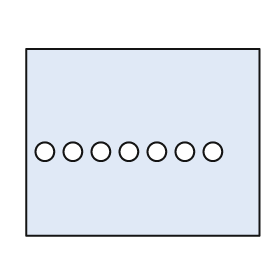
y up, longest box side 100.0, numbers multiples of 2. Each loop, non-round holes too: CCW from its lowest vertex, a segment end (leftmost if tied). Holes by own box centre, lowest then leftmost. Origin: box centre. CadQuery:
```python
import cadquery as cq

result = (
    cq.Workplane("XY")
    .moveTo(-50.0, -40.0)
    .lineTo(50.0, -40.0)
    .lineTo(50.0, 40.0)
    .lineTo(-50.0, 40.0)
    .close()
    .moveTo(-42.0, -4.0)
    .circle(4.0)
    .moveTo(-30.0, -4.0)
    .circle(4.0)
    .moveTo(-18.0, -4.0)
    .circle(4.0)
    .moveTo(-6.0, -4.0)
    .circle(4.0)
    .moveTo(6.0, -4.0)
    .circle(4.0)
    .moveTo(18.0, -4.0)
    .circle(4.0)
    .moveTo(30.0, -4.0)
    .circle(4.0)
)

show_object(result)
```